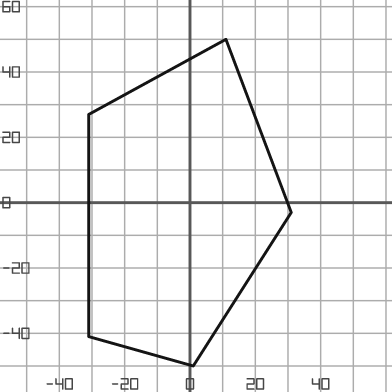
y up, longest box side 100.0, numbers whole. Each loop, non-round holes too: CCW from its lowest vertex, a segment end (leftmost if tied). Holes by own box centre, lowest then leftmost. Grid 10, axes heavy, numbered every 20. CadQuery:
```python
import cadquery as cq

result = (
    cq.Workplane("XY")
    .moveTo(1.0, -50.0)
    .lineTo(31.0, -3.0)
    .lineTo(11.0, 50.0)
    .lineTo(-31.0, 27.0)
    .lineTo(-31.0, -41.0)
    .close()
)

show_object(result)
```